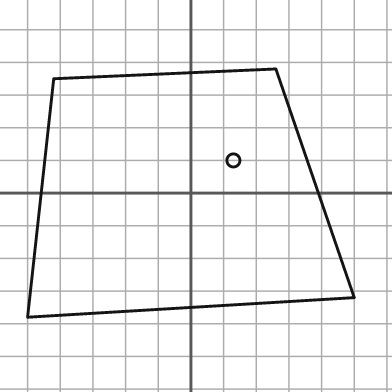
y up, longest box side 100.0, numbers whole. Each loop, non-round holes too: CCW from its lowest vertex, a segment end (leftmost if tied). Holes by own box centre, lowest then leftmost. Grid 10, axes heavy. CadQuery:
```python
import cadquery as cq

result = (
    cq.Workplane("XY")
    .moveTo(-50.0, -38.0)
    .lineTo(50.0, -32.0)
    .lineTo(26.0, 38.0)
    .lineTo(-42.0, 35.0)
    .close()
    .moveTo(13.0, 10.0)
    .circle(2.0)
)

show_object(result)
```